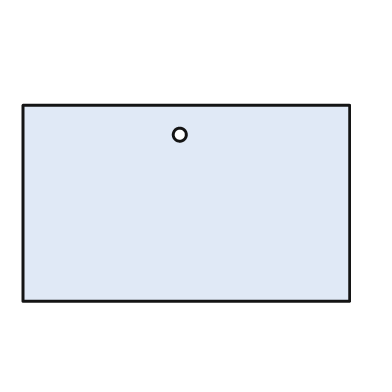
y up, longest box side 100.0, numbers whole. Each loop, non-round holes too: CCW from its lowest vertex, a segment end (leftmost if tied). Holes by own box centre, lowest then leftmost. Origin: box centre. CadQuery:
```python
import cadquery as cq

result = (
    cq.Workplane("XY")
    .moveTo(-50.0, -30.0)
    .lineTo(50.0, -30.0)
    .lineTo(50.0, 30.0)
    .lineTo(-50.0, 30.0)
    .close()
    .moveTo(-2.0, 21.0)
    .circle(2.0)
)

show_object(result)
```